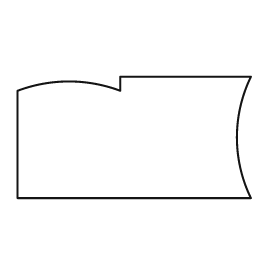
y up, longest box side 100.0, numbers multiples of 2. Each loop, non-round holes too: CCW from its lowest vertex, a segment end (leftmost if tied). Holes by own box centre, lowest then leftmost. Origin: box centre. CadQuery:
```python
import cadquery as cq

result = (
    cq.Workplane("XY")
    .moveTo(-50.0, -26.0)
    .lineTo(50.0, -26.0)
    .threePointArc((44.0, 0.0), (50.0, 26.0))
    .lineTo(-6.0, 26.0)
    .lineTo(-6.0, 20.0)
    .threePointArc((-28.0, 24.0), (-50.0, 20.0))
    .close()
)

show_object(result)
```